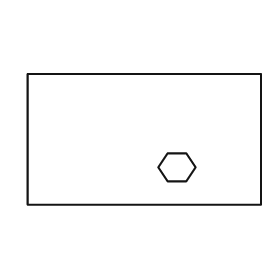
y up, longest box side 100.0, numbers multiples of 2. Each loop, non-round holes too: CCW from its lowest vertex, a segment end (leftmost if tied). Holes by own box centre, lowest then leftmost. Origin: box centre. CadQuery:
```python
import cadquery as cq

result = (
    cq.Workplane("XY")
    .moveTo(-50.0, -28.0)
    .lineTo(50.0, -28.0)
    .lineTo(50.0, 28.0)
    .lineTo(-50.0, 28.0)
    .close()
    .moveTo(10.0, -18.0)
    .lineTo(18.0, -18.0)
    .lineTo(22.0, -12.0)
    .lineTo(18.0, -6.0)
    .lineTo(10.0, -6.0)
    .lineTo(6.0, -12.0)
    .close()
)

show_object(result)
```